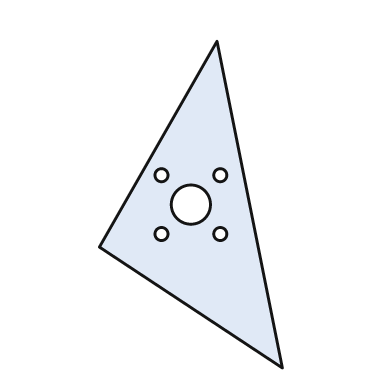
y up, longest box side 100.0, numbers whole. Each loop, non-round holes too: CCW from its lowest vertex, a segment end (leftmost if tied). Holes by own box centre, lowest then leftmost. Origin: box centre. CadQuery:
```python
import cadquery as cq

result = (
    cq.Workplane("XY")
    .moveTo(28.0, -50.0)
    .lineTo(8.0, 50.0)
    .lineTo(-28.0, -13.0)
    .close()
    .moveTo(-9.0, -9.0)
    .circle(2.0)
    .moveTo(9.0, -9.0)
    .circle(2.0)
    .moveTo(0.0, 0.0)
    .circle(6.0)
    .moveTo(-9.0, 9.0)
    .circle(2.0)
    .moveTo(9.0, 9.0)
    .circle(2.0)
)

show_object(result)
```